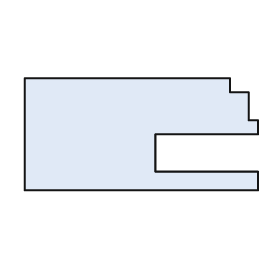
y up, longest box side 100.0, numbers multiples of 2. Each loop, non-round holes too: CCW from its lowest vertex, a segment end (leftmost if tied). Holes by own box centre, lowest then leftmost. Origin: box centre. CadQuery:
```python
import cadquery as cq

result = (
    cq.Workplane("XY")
    .moveTo(-50.0, -24.0)
    .lineTo(50.0, -24.0)
    .lineTo(50.0, -16.0)
    .lineTo(6.0, -16.0)
    .lineTo(6.0, 0.0)
    .lineTo(50.0, 0.0)
    .lineTo(50.0, 6.0)
    .lineTo(46.0, 6.0)
    .lineTo(46.0, 18.0)
    .lineTo(38.0, 18.0)
    .lineTo(38.0, 24.0)
    .lineTo(-50.0, 24.0)
    .close()
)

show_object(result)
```